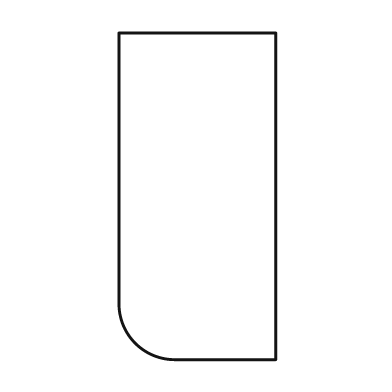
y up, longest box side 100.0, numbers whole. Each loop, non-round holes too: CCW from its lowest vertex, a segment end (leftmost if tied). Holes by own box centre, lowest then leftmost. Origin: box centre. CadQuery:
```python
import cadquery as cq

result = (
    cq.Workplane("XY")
    .moveTo(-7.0, -50.0)
    .lineTo(24.0, -50.0)
    .lineTo(24.0, 50.0)
    .lineTo(-24.0, 50.0)
    .lineTo(-24.0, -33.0)
    .threePointArc((-19.0, -45.0), (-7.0, -50.0))
    .close()
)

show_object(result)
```